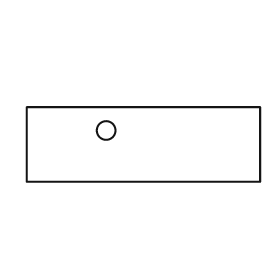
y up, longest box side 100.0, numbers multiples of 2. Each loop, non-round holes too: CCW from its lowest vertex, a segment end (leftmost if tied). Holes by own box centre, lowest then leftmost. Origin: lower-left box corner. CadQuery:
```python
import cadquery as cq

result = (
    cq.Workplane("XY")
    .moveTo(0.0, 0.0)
    .lineTo(100.0, 0.0)
    .lineTo(100.0, 32.0)
    .lineTo(0.0, 32.0)
    .close()
    .moveTo(34.0, 22.0)
    .circle(4.0)
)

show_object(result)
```